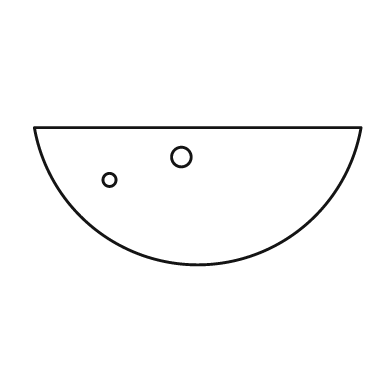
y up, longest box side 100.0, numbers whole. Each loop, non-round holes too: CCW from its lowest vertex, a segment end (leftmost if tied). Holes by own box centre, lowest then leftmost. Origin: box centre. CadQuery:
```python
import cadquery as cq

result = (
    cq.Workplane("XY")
    .moveTo(-50.0, 21.0)
    .threePointArc((0.0, -21.0), (50.0, 21.0))
    .close()
    .moveTo(-27.0, 5.0)
    .circle(2.0)
    .moveTo(-5.0, 12.0)
    .circle(3.0)
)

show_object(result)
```